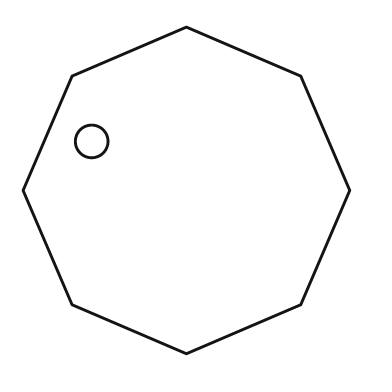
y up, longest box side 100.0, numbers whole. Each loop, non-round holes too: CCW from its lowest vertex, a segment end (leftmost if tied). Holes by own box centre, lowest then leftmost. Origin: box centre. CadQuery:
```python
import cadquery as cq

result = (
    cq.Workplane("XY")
    .moveTo(0.0, -50.0)
    .lineTo(35.0, -35.0)
    .lineTo(50.0, 0.0)
    .lineTo(35.0, 35.0)
    .lineTo(0.0, 50.0)
    .lineTo(-35.0, 35.0)
    .lineTo(-50.0, 0.0)
    .lineTo(-35.0, -35.0)
    .close()
    .moveTo(-29.0, 15.0)
    .circle(5.0)
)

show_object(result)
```